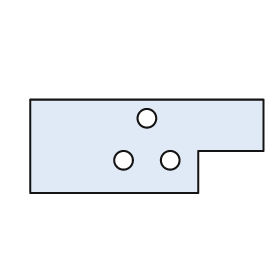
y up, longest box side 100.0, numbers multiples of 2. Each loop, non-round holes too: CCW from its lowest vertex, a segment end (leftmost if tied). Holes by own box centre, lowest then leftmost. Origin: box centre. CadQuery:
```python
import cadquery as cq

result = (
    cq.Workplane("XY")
    .moveTo(-50.0, -20.0)
    .lineTo(22.0, -20.0)
    .lineTo(22.0, -2.0)
    .lineTo(50.0, -2.0)
    .lineTo(50.0, 20.0)
    .lineTo(-50.0, 20.0)
    .close()
    .moveTo(-10.0, -6.0)
    .circle(4.0)
    .moveTo(10.0, -6.0)
    .circle(4.0)
    .moveTo(0.0, 12.0)
    .circle(4.0)
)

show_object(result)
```